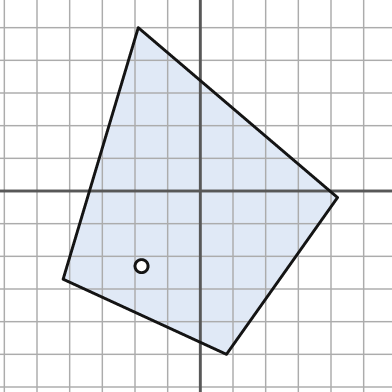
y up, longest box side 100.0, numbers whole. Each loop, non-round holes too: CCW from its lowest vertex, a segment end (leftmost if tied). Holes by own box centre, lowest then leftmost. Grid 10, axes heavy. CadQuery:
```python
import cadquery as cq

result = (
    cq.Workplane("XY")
    .moveTo(8.0, -50.0)
    .lineTo(42.0, -2.0)
    .lineTo(-19.0, 50.0)
    .lineTo(-42.0, -27.0)
    .close()
    .moveTo(-18.0, -23.0)
    .circle(2.0)
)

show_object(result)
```